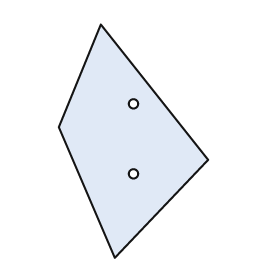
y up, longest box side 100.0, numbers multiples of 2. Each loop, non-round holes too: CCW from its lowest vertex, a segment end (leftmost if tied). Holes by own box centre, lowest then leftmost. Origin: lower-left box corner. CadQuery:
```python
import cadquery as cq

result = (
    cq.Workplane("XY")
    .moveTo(24.0, 0.0)
    .lineTo(64.0, 42.0)
    .lineTo(18.0, 100.0)
    .lineTo(0.0, 56.0)
    .close()
    .moveTo(32.0, 36.0)
    .circle(2.0)
    .moveTo(32.0, 66.0)
    .circle(2.0)
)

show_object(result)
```